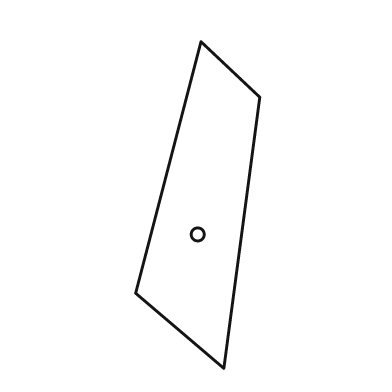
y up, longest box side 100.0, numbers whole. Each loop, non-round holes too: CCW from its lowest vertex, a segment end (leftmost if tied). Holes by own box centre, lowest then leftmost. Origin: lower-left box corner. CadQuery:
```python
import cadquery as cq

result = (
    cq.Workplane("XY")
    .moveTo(27.0, 0.0)
    .lineTo(38.0, 83.0)
    .lineTo(20.0, 100.0)
    .lineTo(0.0, 23.0)
    .close()
    .moveTo(19.0, 41.0)
    .circle(2.0)
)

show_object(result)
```